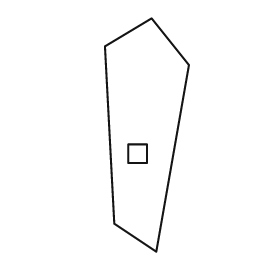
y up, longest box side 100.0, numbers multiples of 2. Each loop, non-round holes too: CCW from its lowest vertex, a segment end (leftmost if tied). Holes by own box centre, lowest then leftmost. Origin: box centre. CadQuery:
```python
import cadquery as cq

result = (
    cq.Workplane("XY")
    .moveTo(4.0, -50.0)
    .lineTo(18.0, 30.0)
    .lineTo(2.0, 50.0)
    .lineTo(-18.0, 38.0)
    .lineTo(-14.0, -38.0)
    .close()
    .moveTo(-8.0, -12.0)
    .lineTo(0.0, -12.0)
    .lineTo(0.0, -4.0)
    .lineTo(-8.0, -4.0)
    .close()
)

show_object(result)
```